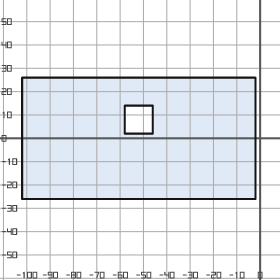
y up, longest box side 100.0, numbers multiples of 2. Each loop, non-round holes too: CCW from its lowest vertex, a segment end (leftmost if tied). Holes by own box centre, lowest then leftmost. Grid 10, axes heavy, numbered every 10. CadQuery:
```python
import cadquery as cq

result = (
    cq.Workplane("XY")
    .moveTo(-102.0, -26.0)
    .lineTo(-2.0, -26.0)
    .lineTo(-2.0, 26.0)
    .lineTo(-102.0, 26.0)
    .close()
    .moveTo(-58.0, 2.0)
    .lineTo(-46.0, 2.0)
    .lineTo(-46.0, 14.0)
    .lineTo(-58.0, 14.0)
    .close()
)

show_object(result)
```